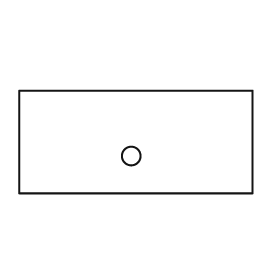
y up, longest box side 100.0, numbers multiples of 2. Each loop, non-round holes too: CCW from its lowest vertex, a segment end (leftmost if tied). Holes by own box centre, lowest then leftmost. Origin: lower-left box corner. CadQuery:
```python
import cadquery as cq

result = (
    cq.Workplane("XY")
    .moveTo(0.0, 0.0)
    .lineTo(100.0, 0.0)
    .lineTo(100.0, 44.0)
    .lineTo(0.0, 44.0)
    .close()
    .moveTo(48.0, 16.0)
    .circle(4.0)
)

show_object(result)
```